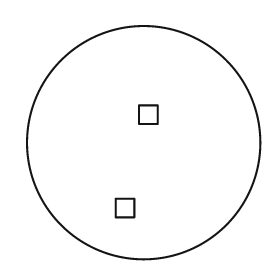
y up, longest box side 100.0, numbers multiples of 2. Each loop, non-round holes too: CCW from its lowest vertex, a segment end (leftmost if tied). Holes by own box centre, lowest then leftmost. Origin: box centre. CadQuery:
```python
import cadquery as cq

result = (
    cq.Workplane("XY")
    .moveTo(0.0, 0.0)
    .circle(50.0)
    .moveTo(-12.0, -32.0)
    .lineTo(-4.0, -32.0)
    .lineTo(-4.0, -24.0)
    .lineTo(-12.0, -24.0)
    .close()
    .moveTo(-2.0, 8.0)
    .lineTo(6.0, 8.0)
    .lineTo(6.0, 16.0)
    .lineTo(-2.0, 16.0)
    .close()
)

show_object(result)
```